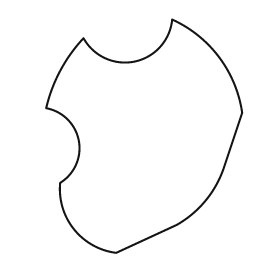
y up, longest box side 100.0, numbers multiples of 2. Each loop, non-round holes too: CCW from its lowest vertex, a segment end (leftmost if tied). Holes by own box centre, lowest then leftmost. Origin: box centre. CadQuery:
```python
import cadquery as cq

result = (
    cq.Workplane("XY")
    .moveTo(-12.0, -50.0)
    .lineTo(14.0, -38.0)
    .threePointArc((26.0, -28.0), (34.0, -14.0))
    .lineTo(42.0, 10.0)
    .threePointArc((32.0, 34.0), (12.0, 50.0))
    .threePointArc((-4.0, 32.0), (-26.0, 42.0))
    .threePointArc((-36.0, 28.0), (-42.0, 12.0))
    .threePointArc((-28.0, -2.0), (-36.0, -20.0))
    .threePointArc((-30.0, -40.0), (-12.0, -50.0))
    .close()
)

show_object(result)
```